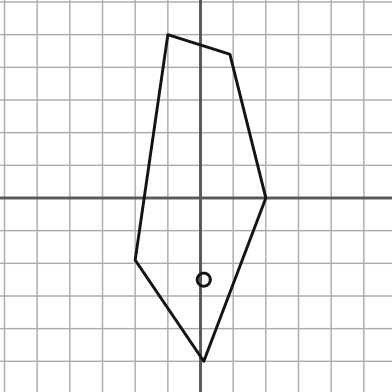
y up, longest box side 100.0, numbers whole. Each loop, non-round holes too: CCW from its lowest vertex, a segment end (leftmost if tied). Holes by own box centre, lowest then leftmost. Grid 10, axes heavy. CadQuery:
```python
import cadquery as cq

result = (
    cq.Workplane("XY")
    .moveTo(1.0, -50.0)
    .lineTo(20.0, 0.0)
    .lineTo(9.0, 44.0)
    .lineTo(-10.0, 50.0)
    .lineTo(-20.0, -19.0)
    .close()
    .moveTo(1.0, -25.0)
    .circle(2.0)
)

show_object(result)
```